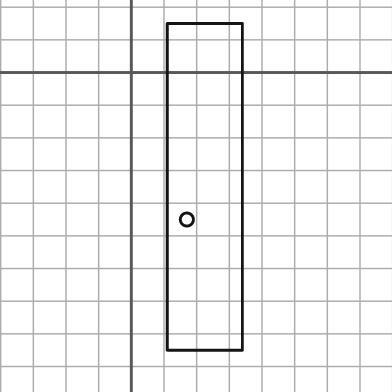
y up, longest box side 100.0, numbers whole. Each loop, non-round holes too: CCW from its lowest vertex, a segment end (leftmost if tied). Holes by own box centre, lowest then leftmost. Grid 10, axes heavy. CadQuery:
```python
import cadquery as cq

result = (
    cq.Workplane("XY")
    .moveTo(11.0, -85.0)
    .lineTo(34.0, -85.0)
    .lineTo(34.0, 15.0)
    .lineTo(11.0, 15.0)
    .close()
    .moveTo(17.0, -45.0)
    .circle(2.0)
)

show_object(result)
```